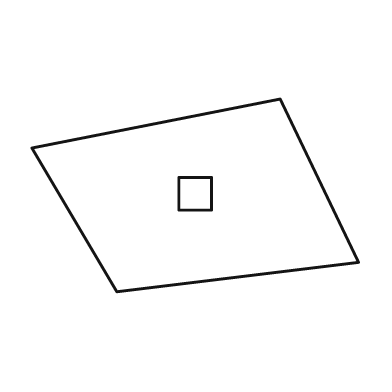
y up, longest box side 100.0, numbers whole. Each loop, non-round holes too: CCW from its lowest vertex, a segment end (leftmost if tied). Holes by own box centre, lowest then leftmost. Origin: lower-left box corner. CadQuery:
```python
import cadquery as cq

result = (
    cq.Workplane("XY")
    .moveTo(26.0, 0.0)
    .lineTo(100.0, 9.0)
    .lineTo(76.0, 59.0)
    .lineTo(0.0, 44.0)
    .close()
    .moveTo(45.0, 25.0)
    .lineTo(55.0, 25.0)
    .lineTo(55.0, 35.0)
    .lineTo(45.0, 35.0)
    .close()
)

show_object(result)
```